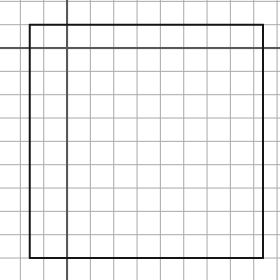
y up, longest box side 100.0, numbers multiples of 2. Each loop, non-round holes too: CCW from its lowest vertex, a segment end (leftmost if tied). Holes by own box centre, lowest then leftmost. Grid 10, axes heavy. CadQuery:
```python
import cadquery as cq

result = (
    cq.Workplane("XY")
    .moveTo(-16.0, -90.0)
    .lineTo(84.0, -90.0)
    .lineTo(84.0, 10.0)
    .lineTo(-16.0, 10.0)
    .close()
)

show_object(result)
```